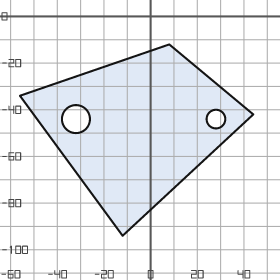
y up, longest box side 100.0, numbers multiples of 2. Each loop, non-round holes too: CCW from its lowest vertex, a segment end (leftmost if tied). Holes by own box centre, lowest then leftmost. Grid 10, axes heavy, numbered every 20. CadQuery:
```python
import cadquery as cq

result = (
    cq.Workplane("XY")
    .moveTo(-12.0, -94.0)
    .lineTo(44.0, -42.0)
    .lineTo(8.0, -12.0)
    .lineTo(-56.0, -34.0)
    .close()
    .moveTo(-32.0, -44.0)
    .circle(6.0)
    .moveTo(28.0, -44.0)
    .circle(4.0)
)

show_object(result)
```